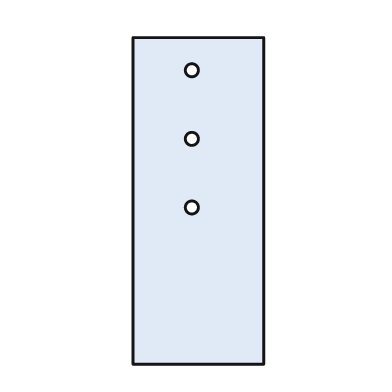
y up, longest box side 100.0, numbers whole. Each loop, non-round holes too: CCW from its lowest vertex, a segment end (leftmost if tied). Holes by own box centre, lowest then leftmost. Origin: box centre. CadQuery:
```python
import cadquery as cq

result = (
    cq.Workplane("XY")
    .moveTo(-20.0, -50.0)
    .lineTo(20.0, -50.0)
    .lineTo(20.0, 50.0)
    .lineTo(-20.0, 50.0)
    .close()
    .moveTo(-2.0, -2.0)
    .circle(2.0)
    .moveTo(-2.0, 19.0)
    .circle(2.0)
    .moveTo(-2.0, 40.0)
    .circle(2.0)
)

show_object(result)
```